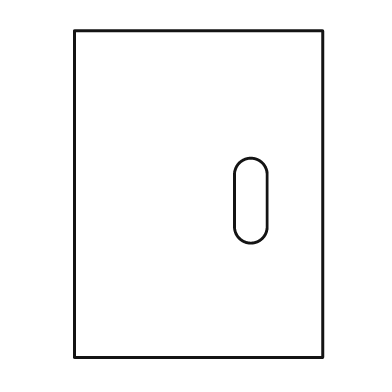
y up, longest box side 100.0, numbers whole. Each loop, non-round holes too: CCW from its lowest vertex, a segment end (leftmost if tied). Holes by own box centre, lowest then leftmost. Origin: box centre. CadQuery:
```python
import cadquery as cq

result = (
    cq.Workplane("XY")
    .moveTo(-38.0, -50.0)
    .lineTo(38.0, -50.0)
    .lineTo(38.0, 50.0)
    .lineTo(-38.0, 50.0)
    .close()
    .moveTo(11.0, -10.0)
    .threePointArc((16.0, -15.0), (21.0, -10.0))
    .lineTo(21.0, 6.0)
    .threePointArc((16.0, 11.0), (11.0, 6.0))
    .close()
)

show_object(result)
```